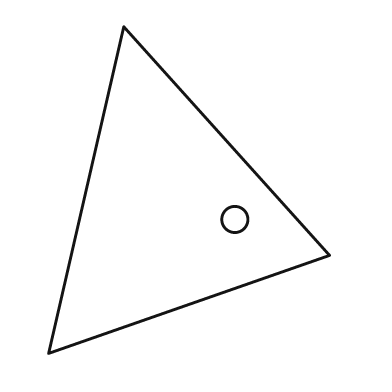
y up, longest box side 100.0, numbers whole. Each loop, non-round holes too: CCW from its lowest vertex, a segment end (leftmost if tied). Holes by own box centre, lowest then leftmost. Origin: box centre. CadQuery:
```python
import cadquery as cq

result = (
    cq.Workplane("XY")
    .moveTo(-43.0, -50.0)
    .lineTo(43.0, -20.0)
    .lineTo(-20.0, 50.0)
    .close()
    .moveTo(14.0, -9.0)
    .circle(4.0)
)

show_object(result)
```